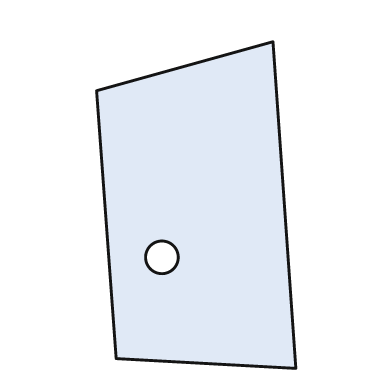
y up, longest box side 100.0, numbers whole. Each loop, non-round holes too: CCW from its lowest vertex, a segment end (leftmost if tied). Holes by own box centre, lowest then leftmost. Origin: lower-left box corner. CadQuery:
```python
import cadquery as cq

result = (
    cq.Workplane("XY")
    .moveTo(61.0, 0.0)
    .lineTo(54.0, 100.0)
    .lineTo(0.0, 85.0)
    .lineTo(6.0, 3.0)
    .close()
    .moveTo(20.0, 34.0)
    .circle(5.0)
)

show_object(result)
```